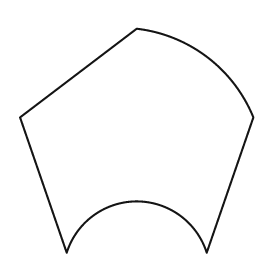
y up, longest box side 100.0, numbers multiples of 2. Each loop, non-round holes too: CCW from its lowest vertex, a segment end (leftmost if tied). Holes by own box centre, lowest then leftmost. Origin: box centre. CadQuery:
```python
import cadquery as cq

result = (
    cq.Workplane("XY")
    .moveTo(-30.0, -48.0)
    .threePointArc((0.0, -26.0), (30.0, -48.0))
    .lineTo(50.0, 10.0)
    .threePointArc((30.0, 36.0), (0.0, 48.0))
    .lineTo(-50.0, 10.0)
    .close()
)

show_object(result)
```